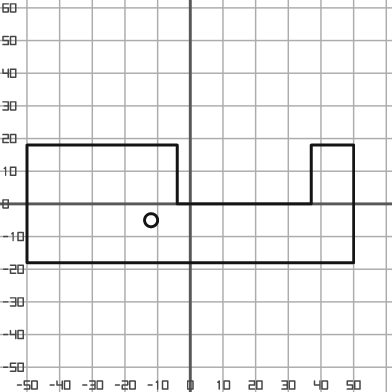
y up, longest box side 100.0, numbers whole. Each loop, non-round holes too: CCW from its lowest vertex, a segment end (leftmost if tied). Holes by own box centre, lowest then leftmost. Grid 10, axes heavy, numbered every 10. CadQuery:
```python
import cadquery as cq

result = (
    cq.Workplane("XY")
    .moveTo(-50.0, -18.0)
    .lineTo(50.0, -18.0)
    .lineTo(50.0, 18.0)
    .lineTo(37.0, 18.0)
    .lineTo(37.0, 0.0)
    .lineTo(-4.0, 0.0)
    .lineTo(-4.0, 18.0)
    .lineTo(-50.0, 18.0)
    .close()
    .moveTo(-12.0, -5.0)
    .circle(2.0)
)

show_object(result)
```